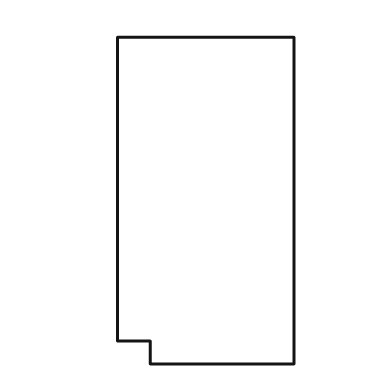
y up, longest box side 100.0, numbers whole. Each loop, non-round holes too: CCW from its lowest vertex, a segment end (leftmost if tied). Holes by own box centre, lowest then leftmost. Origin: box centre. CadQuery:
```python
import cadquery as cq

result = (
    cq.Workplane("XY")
    .moveTo(-17.0, -50.0)
    .lineTo(27.0, -50.0)
    .lineTo(27.0, 50.0)
    .lineTo(-27.0, 50.0)
    .lineTo(-27.0, -43.0)
    .lineTo(-17.0, -43.0)
    .close()
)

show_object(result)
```